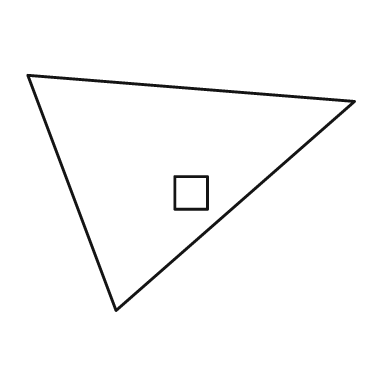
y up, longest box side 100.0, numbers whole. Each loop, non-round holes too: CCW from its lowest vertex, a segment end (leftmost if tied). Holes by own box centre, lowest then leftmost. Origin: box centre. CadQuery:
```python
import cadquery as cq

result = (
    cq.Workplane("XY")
    .moveTo(-23.0, -36.0)
    .lineTo(50.0, 28.0)
    .lineTo(-50.0, 36.0)
    .close()
    .moveTo(-5.0, -5.0)
    .lineTo(5.0, -5.0)
    .lineTo(5.0, 5.0)
    .lineTo(-5.0, 5.0)
    .close()
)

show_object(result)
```